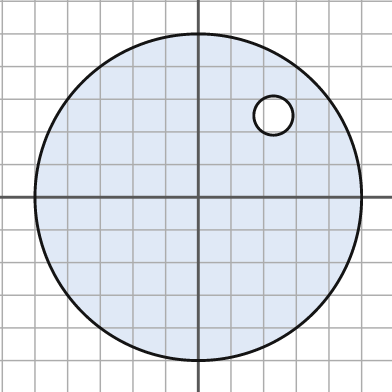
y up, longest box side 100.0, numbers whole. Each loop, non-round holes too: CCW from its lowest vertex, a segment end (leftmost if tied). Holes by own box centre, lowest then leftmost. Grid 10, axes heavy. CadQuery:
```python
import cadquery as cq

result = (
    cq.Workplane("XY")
    .moveTo(0.0, 0.0)
    .circle(50.0)
    .moveTo(23.0, 25.0)
    .circle(6.0)
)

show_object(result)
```